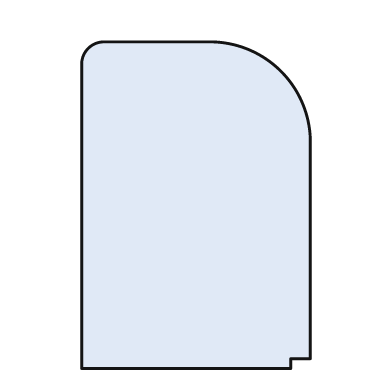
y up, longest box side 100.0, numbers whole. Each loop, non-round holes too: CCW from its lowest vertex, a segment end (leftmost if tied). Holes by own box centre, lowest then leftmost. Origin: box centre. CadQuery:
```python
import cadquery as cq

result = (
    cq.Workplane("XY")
    .moveTo(-35.0, -50.0)
    .lineTo(29.0, -50.0)
    .lineTo(29.0, -47.0)
    .lineTo(35.0, -47.0)
    .lineTo(35.0, 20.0)
    .threePointArc((26.0, 41.0), (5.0, 50.0))
    .lineTo(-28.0, 50.0)
    .threePointArc((-33.0, 48.0), (-35.0, 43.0))
    .close()
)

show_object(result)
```